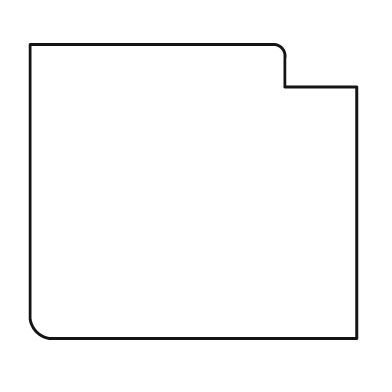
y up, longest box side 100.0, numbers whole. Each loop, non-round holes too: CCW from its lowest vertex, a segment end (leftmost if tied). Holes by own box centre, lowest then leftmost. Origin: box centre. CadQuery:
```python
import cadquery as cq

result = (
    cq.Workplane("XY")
    .moveTo(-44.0, -45.0)
    .lineTo(50.0, -45.0)
    .lineTo(50.0, 32.0)
    .lineTo(28.0, 32.0)
    .lineTo(28.0, 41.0)
    .threePointArc((27.0, 44.0), (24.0, 45.0))
    .lineTo(-50.0, 45.0)
    .lineTo(-50.0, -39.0)
    .threePointArc((-48.0, -43.0), (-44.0, -45.0))
    .close()
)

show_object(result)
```